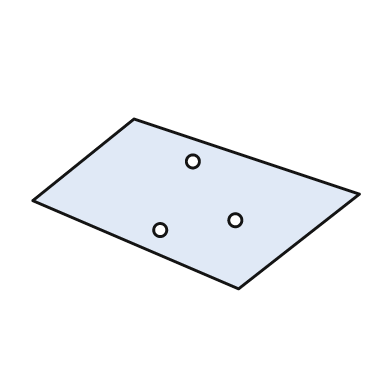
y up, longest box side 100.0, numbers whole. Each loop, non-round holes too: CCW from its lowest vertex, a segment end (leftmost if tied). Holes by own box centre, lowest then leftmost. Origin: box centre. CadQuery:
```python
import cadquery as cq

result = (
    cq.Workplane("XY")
    .moveTo(13.0, -26.0)
    .lineTo(50.0, 3.0)
    .lineTo(-19.0, 26.0)
    .lineTo(-50.0, 1.0)
    .close()
    .moveTo(-11.0, -8.0)
    .circle(2.0)
    .moveTo(12.0, -5.0)
    .circle(2.0)
    .moveTo(-1.0, 13.0)
    .circle(2.0)
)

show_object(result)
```